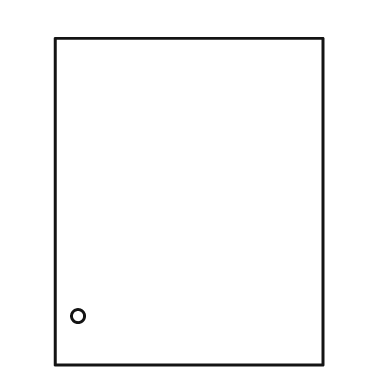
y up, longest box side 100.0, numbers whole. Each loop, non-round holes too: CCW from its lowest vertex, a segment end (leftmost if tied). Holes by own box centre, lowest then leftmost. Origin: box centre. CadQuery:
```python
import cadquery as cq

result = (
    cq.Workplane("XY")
    .moveTo(-41.0, -50.0)
    .lineTo(41.0, -50.0)
    .lineTo(41.0, 50.0)
    .lineTo(-41.0, 50.0)
    .close()
    .moveTo(-34.0, -35.0)
    .circle(2.0)
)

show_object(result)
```